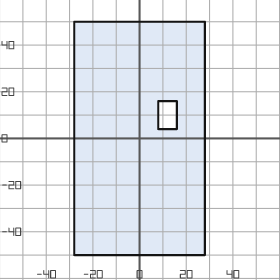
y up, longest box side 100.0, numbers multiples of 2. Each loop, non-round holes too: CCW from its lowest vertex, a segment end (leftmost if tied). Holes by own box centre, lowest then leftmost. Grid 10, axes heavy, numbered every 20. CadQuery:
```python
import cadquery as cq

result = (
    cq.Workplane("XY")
    .moveTo(-28.0, -50.0)
    .lineTo(28.0, -50.0)
    .lineTo(28.0, 50.0)
    .lineTo(-28.0, 50.0)
    .close()
    .moveTo(8.0, 4.0)
    .lineTo(16.0, 4.0)
    .lineTo(16.0, 16.0)
    .lineTo(8.0, 16.0)
    .close()
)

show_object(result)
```